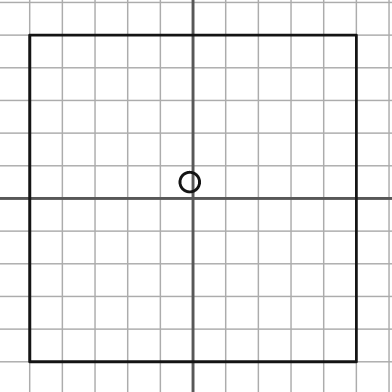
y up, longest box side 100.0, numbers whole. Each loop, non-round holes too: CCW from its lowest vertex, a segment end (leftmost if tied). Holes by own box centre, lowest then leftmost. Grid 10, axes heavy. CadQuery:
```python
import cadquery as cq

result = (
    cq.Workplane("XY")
    .moveTo(-50.0, -50.0)
    .lineTo(50.0, -50.0)
    .lineTo(50.0, 50.0)
    .lineTo(-50.0, 50.0)
    .close()
    .moveTo(-1.0, 5.0)
    .circle(3.0)
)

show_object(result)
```